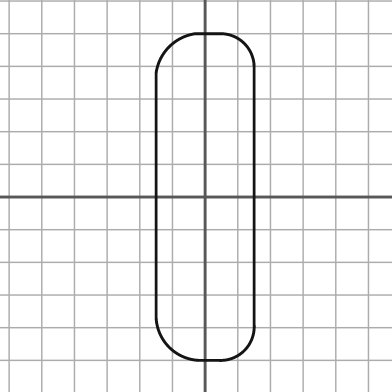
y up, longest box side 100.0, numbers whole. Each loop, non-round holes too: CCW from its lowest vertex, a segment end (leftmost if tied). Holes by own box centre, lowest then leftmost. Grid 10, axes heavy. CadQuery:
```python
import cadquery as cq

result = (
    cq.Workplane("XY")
    .moveTo(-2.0, -50.0)
    .lineTo(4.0, -50.0)
    .threePointArc((12.0, -47.0), (15.0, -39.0))
    .lineTo(15.0, 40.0)
    .threePointArc((12.0, 47.0), (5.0, 50.0))
    .lineTo(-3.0, 50.0)
    .threePointArc((-11.0, 46.0), (-15.0, 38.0))
    .lineTo(-15.0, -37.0)
    .threePointArc((-11.0, -46.0), (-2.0, -50.0))
    .close()
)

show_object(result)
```